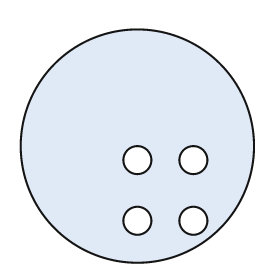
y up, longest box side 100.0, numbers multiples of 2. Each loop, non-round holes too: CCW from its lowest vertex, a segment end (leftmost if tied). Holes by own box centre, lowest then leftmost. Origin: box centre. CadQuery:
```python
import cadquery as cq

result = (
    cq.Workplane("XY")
    .moveTo(0.0, 0.0)
    .circle(50.0)
    .moveTo(0.0, -32.0)
    .circle(6.0)
    .moveTo(24.0, -32.0)
    .circle(6.0)
    .moveTo(0.0, -6.0)
    .circle(6.0)
    .moveTo(24.0, -6.0)
    .circle(6.0)
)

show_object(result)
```